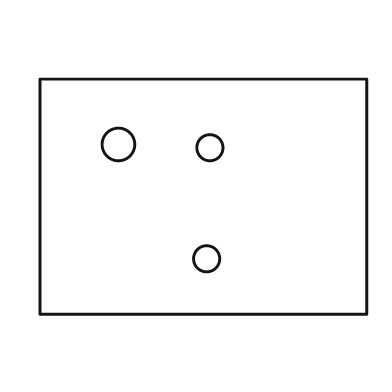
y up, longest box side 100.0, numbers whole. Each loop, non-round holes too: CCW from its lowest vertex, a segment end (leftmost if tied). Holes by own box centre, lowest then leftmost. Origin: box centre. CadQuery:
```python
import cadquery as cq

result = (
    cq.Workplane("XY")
    .moveTo(-50.0, -36.0)
    .lineTo(50.0, -36.0)
    .lineTo(50.0, 36.0)
    .lineTo(-50.0, 36.0)
    .close()
    .moveTo(1.0, -19.0)
    .circle(4.0)
    .moveTo(2.0, 15.0)
    .circle(4.0)
    .moveTo(-26.0, 16.0)
    .circle(5.0)
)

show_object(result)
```